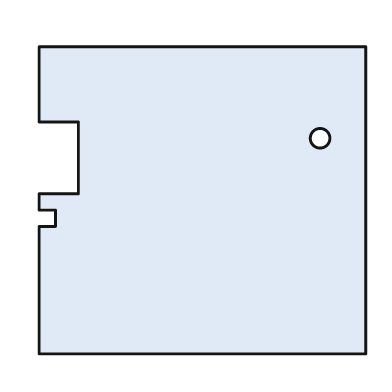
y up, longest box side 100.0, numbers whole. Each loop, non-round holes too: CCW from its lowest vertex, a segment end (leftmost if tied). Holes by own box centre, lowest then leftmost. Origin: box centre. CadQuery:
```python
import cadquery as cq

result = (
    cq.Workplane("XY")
    .moveTo(-50.0, -47.0)
    .lineTo(50.0, -47.0)
    .lineTo(50.0, 47.0)
    .lineTo(-50.0, 47.0)
    .lineTo(-50.0, 24.0)
    .lineTo(-38.0, 24.0)
    .lineTo(-38.0, 2.0)
    .lineTo(-50.0, 2.0)
    .lineTo(-50.0, -3.0)
    .lineTo(-45.0, -3.0)
    .lineTo(-45.0, -8.0)
    .lineTo(-50.0, -8.0)
    .close()
    .moveTo(36.0, 19.0)
    .circle(3.0)
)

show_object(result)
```